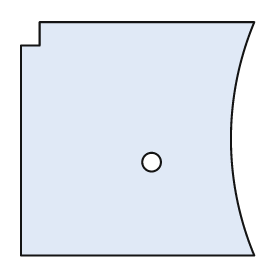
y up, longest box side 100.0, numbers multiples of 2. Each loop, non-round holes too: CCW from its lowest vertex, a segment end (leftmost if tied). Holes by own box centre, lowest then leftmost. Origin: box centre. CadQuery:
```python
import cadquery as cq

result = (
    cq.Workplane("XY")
    .moveTo(-50.0, -50.0)
    .lineTo(50.0, -50.0)
    .threePointArc((40.0, 0.0), (50.0, 50.0))
    .lineTo(-42.0, 50.0)
    .lineTo(-42.0, 40.0)
    .lineTo(-50.0, 40.0)
    .close()
    .moveTo(6.0, -10.0)
    .circle(4.0)
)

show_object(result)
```